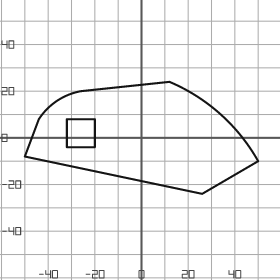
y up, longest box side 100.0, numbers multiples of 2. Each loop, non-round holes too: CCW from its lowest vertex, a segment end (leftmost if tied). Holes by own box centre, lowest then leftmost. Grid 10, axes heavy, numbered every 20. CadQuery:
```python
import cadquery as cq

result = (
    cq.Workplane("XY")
    .moveTo(26.0, -24.0)
    .lineTo(50.0, -10.0)
    .threePointArc((34.0, 10.0), (12.0, 24.0))
    .lineTo(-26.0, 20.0)
    .threePointArc((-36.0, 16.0), (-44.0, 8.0))
    .lineTo(-50.0, -8.0)
    .close()
    .moveTo(-32.0, -4.0)
    .lineTo(-20.0, -4.0)
    .lineTo(-20.0, 8.0)
    .lineTo(-32.0, 8.0)
    .close()
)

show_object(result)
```